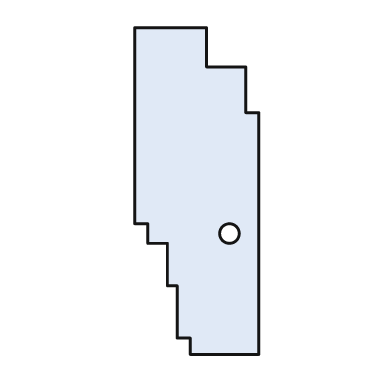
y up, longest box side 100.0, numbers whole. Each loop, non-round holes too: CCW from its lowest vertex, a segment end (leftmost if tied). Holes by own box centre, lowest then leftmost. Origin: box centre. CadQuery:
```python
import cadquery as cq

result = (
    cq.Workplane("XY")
    .moveTo(-2.0, -50.0)
    .lineTo(19.0, -50.0)
    .lineTo(19.0, 24.0)
    .lineTo(15.0, 24.0)
    .lineTo(15.0, 38.0)
    .lineTo(3.0, 38.0)
    .lineTo(3.0, 50.0)
    .lineTo(-19.0, 50.0)
    .lineTo(-19.0, -10.0)
    .lineTo(-15.0, -10.0)
    .lineTo(-15.0, -16.0)
    .lineTo(-9.0, -16.0)
    .lineTo(-9.0, -29.0)
    .lineTo(-6.0, -29.0)
    .lineTo(-6.0, -45.0)
    .lineTo(-2.0, -45.0)
    .close()
    .moveTo(10.0, -13.0)
    .circle(3.0)
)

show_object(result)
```